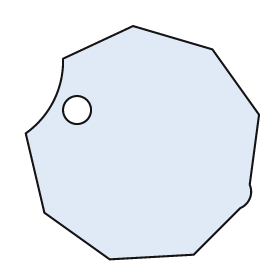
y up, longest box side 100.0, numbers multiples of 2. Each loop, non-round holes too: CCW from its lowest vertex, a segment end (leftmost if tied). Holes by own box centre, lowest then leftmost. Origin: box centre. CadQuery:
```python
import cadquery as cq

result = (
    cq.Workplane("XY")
    .moveTo(-14.0, -50.0)
    .lineTo(22.0, -48.0)
    .lineTo(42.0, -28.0)
    .threePointArc((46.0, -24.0), (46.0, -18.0))
    .lineTo(50.0, 12.0)
    .lineTo(30.0, 40.0)
    .lineTo(-4.0, 50.0)
    .lineTo(-34.0, 36.0)
    .threePointArc((-38.0, 18.0), (-50.0, 4.0))
    .lineTo(-42.0, -30.0)
    .close()
    .moveTo(-28.0, 14.0)
    .circle(6.0)
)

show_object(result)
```